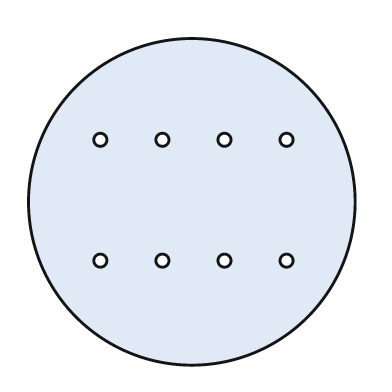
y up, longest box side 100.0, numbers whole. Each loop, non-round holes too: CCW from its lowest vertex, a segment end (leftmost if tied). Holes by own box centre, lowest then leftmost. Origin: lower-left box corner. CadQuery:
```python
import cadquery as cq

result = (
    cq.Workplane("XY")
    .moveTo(50.0, 50.0)
    .circle(50.0)
    .moveTo(22.0, 32.0)
    .circle(2.0)
    .moveTo(41.0, 32.0)
    .circle(2.0)
    .moveTo(60.0, 32.0)
    .circle(2.0)
    .moveTo(79.0, 32.0)
    .circle(2.0)
    .moveTo(22.0, 69.0)
    .circle(2.0)
    .moveTo(41.0, 69.0)
    .circle(2.0)
    .moveTo(60.0, 69.0)
    .circle(2.0)
    .moveTo(79.0, 69.0)
    .circle(2.0)
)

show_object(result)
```